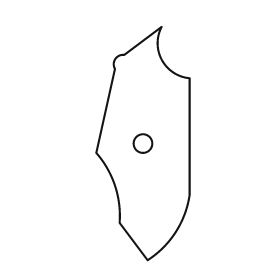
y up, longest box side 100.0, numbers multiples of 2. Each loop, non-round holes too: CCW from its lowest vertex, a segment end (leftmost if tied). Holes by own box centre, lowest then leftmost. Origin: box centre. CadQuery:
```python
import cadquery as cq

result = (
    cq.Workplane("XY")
    .moveTo(2.0, -50.0)
    .threePointArc((14.0, -38.0), (20.0, -22.0))
    .lineTo(20.0, 28.0)
    .threePointArc((8.0, 36.0), (8.0, 50.0))
    .lineTo(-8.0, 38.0)
    .threePointArc((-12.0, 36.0), (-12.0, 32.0))
    .lineTo(-20.0, -4.0)
    .threePointArc((-12.0, -18.0), (-10.0, -34.0))
    .close()
    .moveTo(0.0, 0.0)
    .circle(4.0)
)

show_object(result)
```